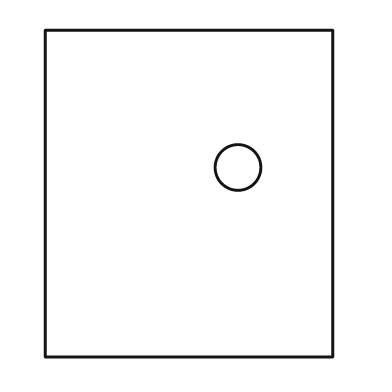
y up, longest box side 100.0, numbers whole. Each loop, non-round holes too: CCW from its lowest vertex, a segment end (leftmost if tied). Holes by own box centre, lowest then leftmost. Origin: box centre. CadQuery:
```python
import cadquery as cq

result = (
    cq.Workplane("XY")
    .moveTo(-44.0, -50.0)
    .lineTo(44.0, -50.0)
    .lineTo(44.0, 50.0)
    .lineTo(-44.0, 50.0)
    .close()
    .moveTo(15.0, 8.0)
    .circle(7.0)
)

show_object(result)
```